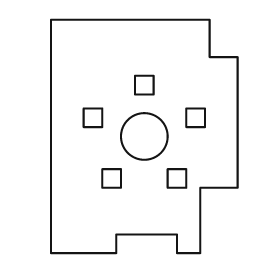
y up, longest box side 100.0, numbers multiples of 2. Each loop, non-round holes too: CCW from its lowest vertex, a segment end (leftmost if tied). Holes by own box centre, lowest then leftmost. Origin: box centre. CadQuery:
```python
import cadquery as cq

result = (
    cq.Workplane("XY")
    .moveTo(-40.0, -50.0)
    .lineTo(-12.0, -50.0)
    .lineTo(-12.0, -42.0)
    .lineTo(14.0, -42.0)
    .lineTo(14.0, -50.0)
    .lineTo(24.0, -50.0)
    .lineTo(24.0, -22.0)
    .lineTo(40.0, -22.0)
    .lineTo(40.0, 34.0)
    .lineTo(28.0, 34.0)
    .lineTo(28.0, 50.0)
    .lineTo(-40.0, 50.0)
    .close()
    .moveTo(-18.0, -22.0)
    .lineTo(-10.0, -22.0)
    .lineTo(-10.0, -14.0)
    .lineTo(-18.0, -14.0)
    .close()
    .moveTo(10.0, -22.0)
    .lineTo(18.0, -22.0)
    .lineTo(18.0, -14.0)
    .lineTo(10.0, -14.0)
    .close()
    .moveTo(0.0, 0.0)
    .circle(10.0)
    .moveTo(-26.0, 4.0)
    .lineTo(-18.0, 4.0)
    .lineTo(-18.0, 12.0)
    .lineTo(-26.0, 12.0)
    .close()
    .moveTo(18.0, 4.0)
    .lineTo(26.0, 4.0)
    .lineTo(26.0, 12.0)
    .lineTo(18.0, 12.0)
    .close()
    .moveTo(-4.0, 18.0)
    .lineTo(4.0, 18.0)
    .lineTo(4.0, 26.0)
    .lineTo(-4.0, 26.0)
    .close()
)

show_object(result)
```